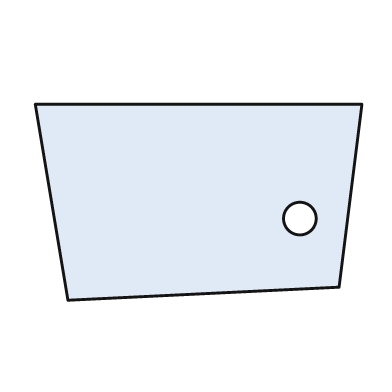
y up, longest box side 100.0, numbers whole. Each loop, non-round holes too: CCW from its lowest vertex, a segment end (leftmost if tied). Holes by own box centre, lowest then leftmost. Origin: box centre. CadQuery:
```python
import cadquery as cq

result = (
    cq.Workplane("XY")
    .moveTo(-40.0, -30.0)
    .lineTo(43.0, -26.0)
    .lineTo(50.0, 30.0)
    .lineTo(-50.0, 30.0)
    .close()
    .moveTo(31.0, -5.0)
    .circle(5.0)
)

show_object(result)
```